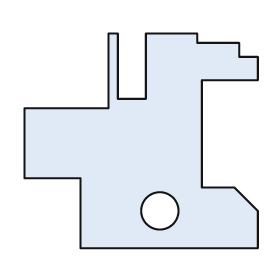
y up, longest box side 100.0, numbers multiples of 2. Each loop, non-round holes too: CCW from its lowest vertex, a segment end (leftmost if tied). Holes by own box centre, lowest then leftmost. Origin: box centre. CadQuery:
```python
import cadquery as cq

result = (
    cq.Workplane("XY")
    .moveTo(-26.0, -46.0)
    .lineTo(50.0, -46.0)
    .lineTo(50.0, -30.0)
    .lineTo(40.0, -20.0)
    .lineTo(26.0, -20.0)
    .lineTo(26.0, 26.0)
    .lineTo(50.0, 26.0)
    .lineTo(50.0, 36.0)
    .lineTo(42.0, 36.0)
    .lineTo(42.0, 42.0)
    .lineTo(24.0, 42.0)
    .lineTo(24.0, 46.0)
    .lineTo(2.0, 46.0)
    .lineTo(2.0, 18.0)
    .lineTo(-10.0, 18.0)
    .lineTo(-10.0, 46.0)
    .lineTo(-14.0, 46.0)
    .lineTo(-14.0, 14.0)
    .lineTo(-50.0, 14.0)
    .lineTo(-50.0, -16.0)
    .lineTo(-26.0, -16.0)
    .close()
    .moveTo(8.0, -30.0)
    .circle(8.0)
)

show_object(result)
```